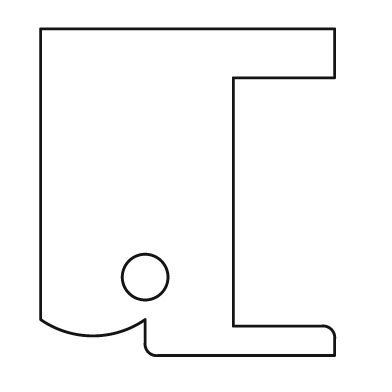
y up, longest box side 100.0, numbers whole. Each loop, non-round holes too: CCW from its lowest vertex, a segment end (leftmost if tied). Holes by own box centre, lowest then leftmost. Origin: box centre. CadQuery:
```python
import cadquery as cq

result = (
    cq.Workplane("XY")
    .moveTo(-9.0, -50.0)
    .lineTo(45.0, -50.0)
    .lineTo(45.0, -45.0)
    .threePointArc((44.0, -42.0), (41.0, -41.0))
    .lineTo(14.0, -41.0)
    .lineTo(14.0, 35.0)
    .lineTo(45.0, 35.0)
    .lineTo(45.0, 50.0)
    .lineTo(-45.0, 50.0)
    .lineTo(-45.0, -39.0)
    .threePointArc((-29.0, -44.0), (-13.0, -39.0))
    .lineTo(-13.0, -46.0)
    .threePointArc((-12.0, -49.0), (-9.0, -50.0))
    .close()
    .moveTo(-13.0, -26.0)
    .circle(7.0)
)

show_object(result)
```